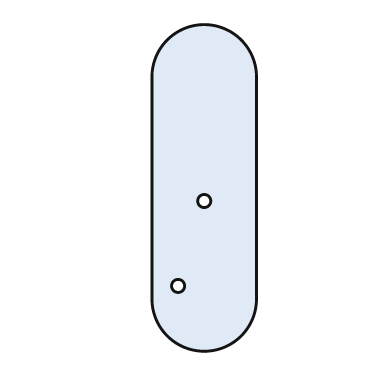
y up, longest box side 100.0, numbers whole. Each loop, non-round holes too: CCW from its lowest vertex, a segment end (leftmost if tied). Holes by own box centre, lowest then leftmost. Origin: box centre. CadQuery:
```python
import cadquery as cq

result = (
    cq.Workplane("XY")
    .moveTo(-16.0, -34.0)
    .threePointArc((0.0, -50.0), (16.0, -34.0))
    .lineTo(16.0, 34.0)
    .threePointArc((0.0, 50.0), (-16.0, 34.0))
    .close()
    .moveTo(-8.0, -30.0)
    .circle(2.0)
    .moveTo(0.0, -4.0)
    .circle(2.0)
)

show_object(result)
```